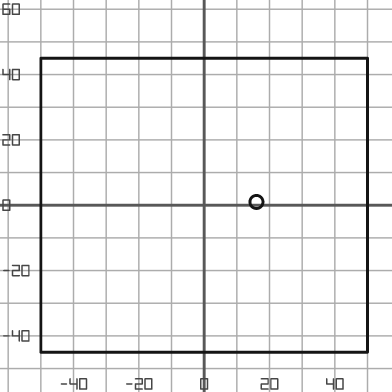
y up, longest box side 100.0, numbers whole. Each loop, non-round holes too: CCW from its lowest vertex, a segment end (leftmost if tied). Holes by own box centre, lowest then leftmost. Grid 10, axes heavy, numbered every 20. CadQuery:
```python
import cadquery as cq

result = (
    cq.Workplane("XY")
    .moveTo(-50.0, -45.0)
    .lineTo(50.0, -45.0)
    .lineTo(50.0, 45.0)
    .lineTo(-50.0, 45.0)
    .close()
    .moveTo(16.0, 1.0)
    .circle(2.0)
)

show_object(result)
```